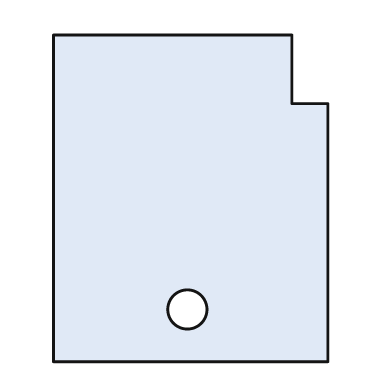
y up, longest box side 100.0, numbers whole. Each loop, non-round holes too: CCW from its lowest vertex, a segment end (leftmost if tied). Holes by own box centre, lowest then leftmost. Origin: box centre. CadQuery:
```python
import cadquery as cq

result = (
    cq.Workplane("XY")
    .moveTo(-42.0, -50.0)
    .lineTo(42.0, -50.0)
    .lineTo(42.0, 29.0)
    .lineTo(31.0, 29.0)
    .lineTo(31.0, 50.0)
    .lineTo(-42.0, 50.0)
    .close()
    .moveTo(-1.0, -34.0)
    .circle(6.0)
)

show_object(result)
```